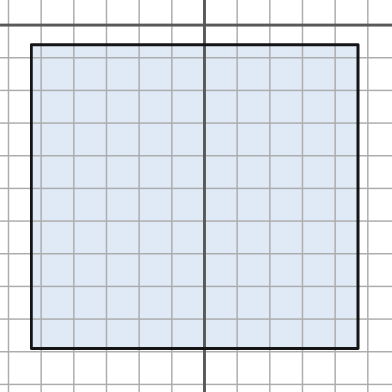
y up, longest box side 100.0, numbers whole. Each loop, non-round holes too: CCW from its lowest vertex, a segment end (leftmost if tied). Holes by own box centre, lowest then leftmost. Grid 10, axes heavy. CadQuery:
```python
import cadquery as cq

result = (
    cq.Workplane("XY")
    .moveTo(-53.0, -99.0)
    .lineTo(47.0, -99.0)
    .lineTo(47.0, -6.0)
    .lineTo(-53.0, -6.0)
    .close()
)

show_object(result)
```